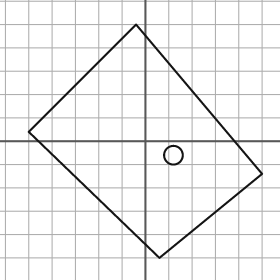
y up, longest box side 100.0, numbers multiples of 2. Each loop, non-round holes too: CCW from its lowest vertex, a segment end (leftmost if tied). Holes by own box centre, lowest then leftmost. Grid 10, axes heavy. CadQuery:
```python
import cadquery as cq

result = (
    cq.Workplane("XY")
    .moveTo(6.0, -50.0)
    .lineTo(50.0, -14.0)
    .lineTo(-4.0, 50.0)
    .lineTo(-50.0, 4.0)
    .close()
    .moveTo(12.0, -6.0)
    .circle(4.0)
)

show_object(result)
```